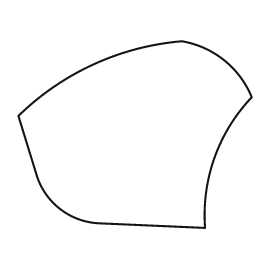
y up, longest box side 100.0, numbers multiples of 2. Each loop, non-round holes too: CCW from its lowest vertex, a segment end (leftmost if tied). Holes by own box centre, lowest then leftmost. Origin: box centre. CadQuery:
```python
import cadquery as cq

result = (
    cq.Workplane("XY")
    .moveTo(30.0, -40.0)
    .threePointArc((34.0, -10.0), (50.0, 16.0))
    .threePointArc((38.0, 32.0), (20.0, 40.0))
    .threePointArc((-18.0, 30.0), (-50.0, 8.0))
    .lineTo(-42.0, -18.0)
    .threePointArc((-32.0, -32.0), (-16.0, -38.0))
    .close()
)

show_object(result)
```